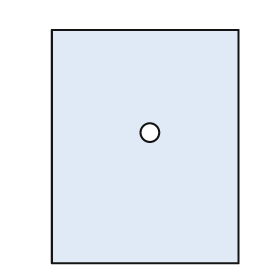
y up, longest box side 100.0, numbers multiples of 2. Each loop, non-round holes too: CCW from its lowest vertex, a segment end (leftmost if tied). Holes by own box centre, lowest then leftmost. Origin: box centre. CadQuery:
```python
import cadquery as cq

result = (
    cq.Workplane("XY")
    .moveTo(-40.0, -50.0)
    .lineTo(40.0, -50.0)
    .lineTo(40.0, 50.0)
    .lineTo(-40.0, 50.0)
    .close()
    .moveTo(2.0, 6.0)
    .circle(4.0)
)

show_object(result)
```